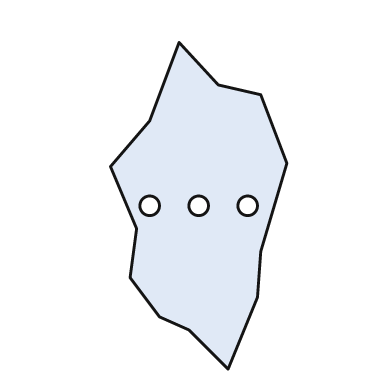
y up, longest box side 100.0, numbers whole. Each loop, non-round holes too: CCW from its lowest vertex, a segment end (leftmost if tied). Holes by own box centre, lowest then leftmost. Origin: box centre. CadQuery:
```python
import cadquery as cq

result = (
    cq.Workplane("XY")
    .moveTo(9.0, -50.0)
    .lineTo(18.0, -28.0)
    .lineTo(19.0, -14.0)
    .lineTo(27.0, 13.0)
    .lineTo(19.0, 34.0)
    .lineTo(6.0, 37.0)
    .lineTo(-6.0, 50.0)
    .lineTo(-15.0, 26.0)
    .lineTo(-27.0, 12.0)
    .lineTo(-19.0, -7.0)
    .lineTo(-21.0, -22.0)
    .lineTo(-12.0, -34.0)
    .lineTo(-3.0, -38.0)
    .close()
    .moveTo(-15.0, 0.0)
    .circle(3.0)
    .moveTo(0.0, 0.0)
    .circle(3.0)
    .moveTo(15.0, 0.0)
    .circle(3.0)
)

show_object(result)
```